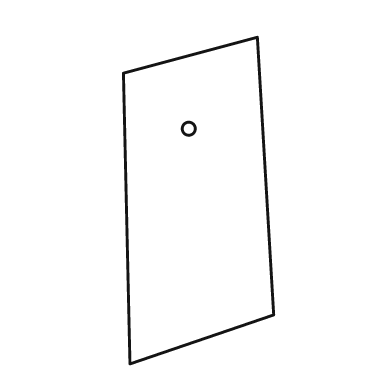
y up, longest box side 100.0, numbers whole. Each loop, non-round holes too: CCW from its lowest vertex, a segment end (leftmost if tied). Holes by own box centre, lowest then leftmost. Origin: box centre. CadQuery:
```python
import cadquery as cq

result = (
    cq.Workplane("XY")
    .moveTo(-21.0, -50.0)
    .lineTo(23.0, -35.0)
    .lineTo(18.0, 50.0)
    .lineTo(-23.0, 39.0)
    .close()
    .moveTo(-3.0, 22.0)
    .circle(2.0)
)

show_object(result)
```